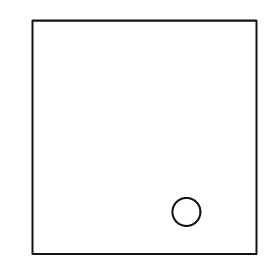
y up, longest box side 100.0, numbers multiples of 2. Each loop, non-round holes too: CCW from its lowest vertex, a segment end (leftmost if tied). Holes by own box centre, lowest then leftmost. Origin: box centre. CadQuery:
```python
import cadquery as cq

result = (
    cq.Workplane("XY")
    .moveTo(-48.0, -50.0)
    .lineTo(48.0, -50.0)
    .lineTo(48.0, 50.0)
    .lineTo(-48.0, 50.0)
    .close()
    .moveTo(18.0, -32.0)
    .circle(6.0)
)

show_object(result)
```